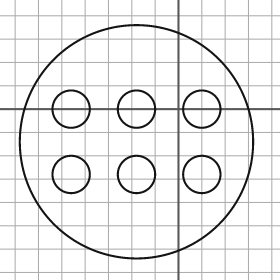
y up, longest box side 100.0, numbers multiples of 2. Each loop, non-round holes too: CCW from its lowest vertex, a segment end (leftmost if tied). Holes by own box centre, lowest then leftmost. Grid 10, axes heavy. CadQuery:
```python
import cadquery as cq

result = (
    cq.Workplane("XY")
    .moveTo(-18.0, -14.0)
    .circle(50.0)
    .moveTo(-46.0, -28.0)
    .circle(8.0)
    .moveTo(-18.0, -28.0)
    .circle(8.0)
    .moveTo(10.0, -28.0)
    .circle(8.0)
    .moveTo(-46.0, 0.0)
    .circle(8.0)
    .moveTo(-18.0, 0.0)
    .circle(8.0)
    .moveTo(10.0, 0.0)
    .circle(8.0)
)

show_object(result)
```